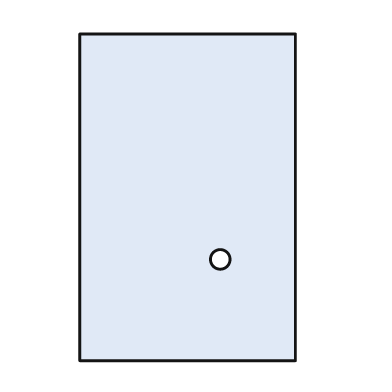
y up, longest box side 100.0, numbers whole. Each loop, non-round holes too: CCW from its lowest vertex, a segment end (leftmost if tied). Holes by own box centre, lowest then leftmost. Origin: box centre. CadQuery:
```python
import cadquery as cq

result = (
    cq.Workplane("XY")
    .moveTo(-33.0, -50.0)
    .lineTo(33.0, -50.0)
    .lineTo(33.0, 50.0)
    .lineTo(-33.0, 50.0)
    .close()
    .moveTo(10.0, -19.0)
    .circle(3.0)
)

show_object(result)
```